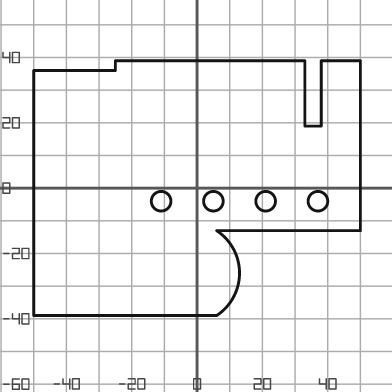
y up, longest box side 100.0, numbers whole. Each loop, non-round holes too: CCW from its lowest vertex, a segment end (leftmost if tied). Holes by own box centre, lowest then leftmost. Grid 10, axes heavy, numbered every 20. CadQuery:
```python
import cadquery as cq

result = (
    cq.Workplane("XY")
    .moveTo(-50.0, -39.0)
    .lineTo(6.0, -39.0)
    .threePointArc((13.0, -26.0), (6.0, -13.0))
    .lineTo(50.0, -13.0)
    .lineTo(50.0, 39.0)
    .lineTo(38.0, 39.0)
    .lineTo(38.0, 19.0)
    .lineTo(33.0, 19.0)
    .lineTo(33.0, 39.0)
    .lineTo(-25.0, 39.0)
    .lineTo(-25.0, 36.0)
    .lineTo(-50.0, 36.0)
    .close()
    .moveTo(-11.0, -4.0)
    .circle(3.0)
    .moveTo(5.0, -4.0)
    .circle(3.0)
    .moveTo(21.0, -4.0)
    .circle(3.0)
    .moveTo(37.0, -4.0)
    .circle(3.0)
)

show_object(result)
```